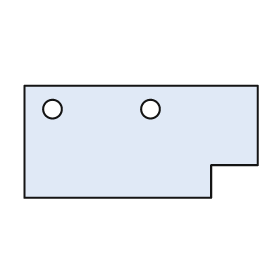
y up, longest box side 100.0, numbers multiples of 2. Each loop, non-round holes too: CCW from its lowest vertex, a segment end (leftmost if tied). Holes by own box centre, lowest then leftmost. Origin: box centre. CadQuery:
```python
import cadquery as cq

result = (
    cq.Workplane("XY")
    .moveTo(-50.0, -24.0)
    .lineTo(30.0, -24.0)
    .lineTo(30.0, -10.0)
    .lineTo(50.0, -10.0)
    .lineTo(50.0, 24.0)
    .lineTo(-50.0, 24.0)
    .close()
    .moveTo(-38.0, 14.0)
    .circle(4.0)
    .moveTo(4.0, 14.0)
    .circle(4.0)
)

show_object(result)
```